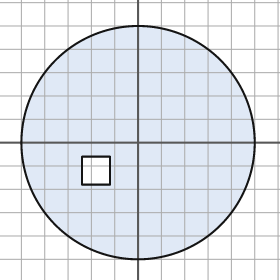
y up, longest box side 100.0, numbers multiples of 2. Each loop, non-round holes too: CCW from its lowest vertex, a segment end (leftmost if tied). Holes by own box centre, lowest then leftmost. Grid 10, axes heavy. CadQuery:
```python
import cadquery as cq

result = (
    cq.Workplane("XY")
    .moveTo(0.0, 0.0)
    .circle(50.0)
    .moveTo(-24.0, -18.0)
    .lineTo(-12.0, -18.0)
    .lineTo(-12.0, -6.0)
    .lineTo(-24.0, -6.0)
    .close()
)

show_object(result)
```